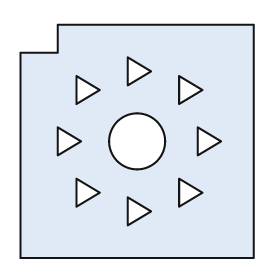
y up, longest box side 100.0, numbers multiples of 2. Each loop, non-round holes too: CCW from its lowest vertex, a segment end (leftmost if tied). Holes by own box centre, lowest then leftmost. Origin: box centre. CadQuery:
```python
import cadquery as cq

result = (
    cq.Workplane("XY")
    .moveTo(-50.0, -50.0)
    .lineTo(50.0, -50.0)
    .lineTo(50.0, 50.0)
    .lineTo(-34.0, 50.0)
    .lineTo(-34.0, 38.0)
    .lineTo(-50.0, 38.0)
    .close()
    .moveTo(-4.0, -36.0)
    .lineTo(6.0, -30.0)
    .lineTo(-4.0, -24.0)
    .close()
    .moveTo(-26.0, -28.0)
    .lineTo(-16.0, -22.0)
    .lineTo(-26.0, -16.0)
    .close()
    .moveTo(18.0, -28.0)
    .lineTo(28.0, -22.0)
    .lineTo(18.0, -16.0)
    .close()
    .moveTo(-34.0, -6.0)
    .lineTo(-24.0, 0.0)
    .lineTo(-34.0, 6.0)
    .close()
    .moveTo(0.0, 0.0)
    .circle(12.0)
    .moveTo(26.0, -6.0)
    .lineTo(36.0, 0.0)
    .lineTo(26.0, 6.0)
    .close()
    .moveTo(-26.0, 16.0)
    .lineTo(-16.0, 22.0)
    .lineTo(-26.0, 28.0)
    .close()
    .moveTo(18.0, 16.0)
    .lineTo(28.0, 22.0)
    .lineTo(18.0, 28.0)
    .close()
    .moveTo(-4.0, 24.0)
    .lineTo(6.0, 30.0)
    .lineTo(-4.0, 36.0)
    .close()
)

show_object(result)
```